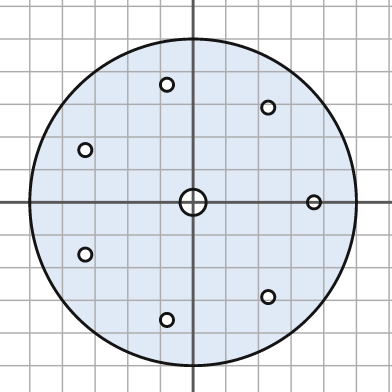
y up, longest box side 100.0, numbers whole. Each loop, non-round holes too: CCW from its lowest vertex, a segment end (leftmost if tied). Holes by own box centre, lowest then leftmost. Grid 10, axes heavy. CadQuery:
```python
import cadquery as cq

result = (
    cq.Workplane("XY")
    .moveTo(0.0, 0.0)
    .circle(50.0)
    .moveTo(-8.0, -36.0)
    .circle(2.0)
    .moveTo(23.0, -29.0)
    .circle(2.0)
    .moveTo(-33.0, -16.0)
    .circle(2.0)
    .moveTo(0.0, 0.0)
    .circle(4.0)
    .moveTo(37.0, 0.0)
    .circle(2.0)
    .moveTo(-33.0, 16.0)
    .circle(2.0)
    .moveTo(23.0, 29.0)
    .circle(2.0)
    .moveTo(-8.0, 36.0)
    .circle(2.0)
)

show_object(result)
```